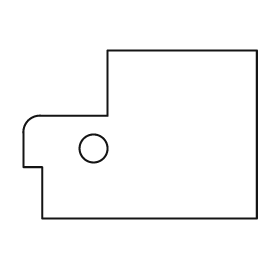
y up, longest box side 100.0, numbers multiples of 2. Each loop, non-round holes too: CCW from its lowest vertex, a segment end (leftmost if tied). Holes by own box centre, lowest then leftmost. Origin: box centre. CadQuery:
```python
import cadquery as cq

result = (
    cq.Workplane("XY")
    .moveTo(-42.0, -36.0)
    .lineTo(50.0, -36.0)
    .lineTo(50.0, 36.0)
    .lineTo(-14.0, 36.0)
    .lineTo(-14.0, 8.0)
    .lineTo(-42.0, 8.0)
    .threePointArc((-48.0, 6.0), (-50.0, 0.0))
    .lineTo(-50.0, -14.0)
    .lineTo(-42.0, -14.0)
    .close()
    .moveTo(-20.0, -6.0)
    .circle(6.0)
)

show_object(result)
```